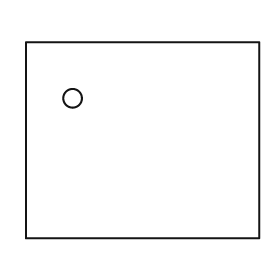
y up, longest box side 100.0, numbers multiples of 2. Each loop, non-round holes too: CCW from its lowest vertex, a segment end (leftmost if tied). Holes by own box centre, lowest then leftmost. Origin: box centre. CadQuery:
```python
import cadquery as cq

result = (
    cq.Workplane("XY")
    .moveTo(-50.0, -42.0)
    .lineTo(50.0, -42.0)
    .lineTo(50.0, 42.0)
    .lineTo(-50.0, 42.0)
    .close()
    .moveTo(-30.0, 18.0)
    .circle(4.0)
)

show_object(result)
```